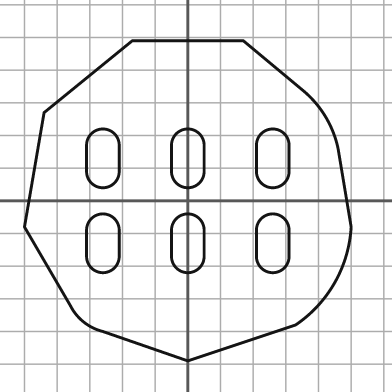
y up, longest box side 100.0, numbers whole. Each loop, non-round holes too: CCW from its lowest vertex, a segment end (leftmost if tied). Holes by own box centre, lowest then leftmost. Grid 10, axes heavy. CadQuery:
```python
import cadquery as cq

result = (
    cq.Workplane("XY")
    .moveTo(0.0, -49.0)
    .lineTo(33.0, -38.0)
    .threePointArc((45.0, -25.0), (50.0, -8.0))
    .lineTo(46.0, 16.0)
    .threePointArc((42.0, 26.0), (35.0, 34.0))
    .lineTo(17.0, 49.0)
    .lineTo(-17.0, 49.0)
    .lineTo(-44.0, 27.0)
    .lineTo(-50.0, -8.0)
    .lineTo(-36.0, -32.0)
    .threePointArc((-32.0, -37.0), (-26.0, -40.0))
    .close()
    .moveTo(-31.0, -17.0)
    .threePointArc((-26.0, -22.0), (-21.0, -17.0))
    .lineTo(-21.0, -9.0)
    .threePointArc((-26.0, -4.0), (-31.0, -9.0))
    .close()
    .moveTo(-5.0, -17.0)
    .threePointArc((0.0, -22.0), (5.0, -17.0))
    .lineTo(5.0, -9.0)
    .threePointArc((0.0, -4.0), (-5.0, -9.0))
    .close()
    .moveTo(21.0, -17.0)
    .threePointArc((26.0, -22.0), (31.0, -17.0))
    .lineTo(31.0, -9.0)
    .threePointArc((26.0, -4.0), (21.0, -9.0))
    .close()
    .moveTo(-31.0, 9.0)
    .threePointArc((-26.0, 4.0), (-21.0, 9.0))
    .lineTo(-21.0, 17.0)
    .threePointArc((-26.0, 22.0), (-31.0, 17.0))
    .close()
    .moveTo(-5.0, 9.0)
    .threePointArc((0.0, 4.0), (5.0, 9.0))
    .lineTo(5.0, 17.0)
    .threePointArc((0.0, 22.0), (-5.0, 17.0))
    .close()
    .moveTo(21.0, 9.0)
    .threePointArc((26.0, 4.0), (31.0, 9.0))
    .lineTo(31.0, 17.0)
    .threePointArc((26.0, 22.0), (21.0, 17.0))
    .close()
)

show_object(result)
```